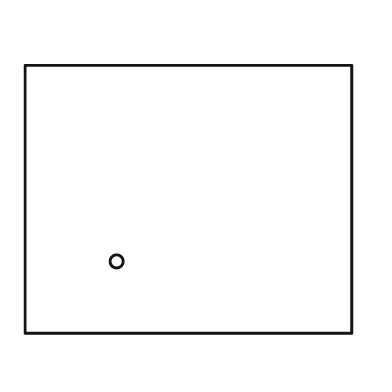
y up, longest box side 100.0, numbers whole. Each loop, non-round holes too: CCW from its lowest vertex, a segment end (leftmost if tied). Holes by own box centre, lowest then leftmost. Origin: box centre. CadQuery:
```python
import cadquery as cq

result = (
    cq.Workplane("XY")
    .moveTo(-50.0, -41.0)
    .lineTo(50.0, -41.0)
    .lineTo(50.0, 41.0)
    .lineTo(-50.0, 41.0)
    .close()
    .moveTo(-22.0, -19.0)
    .circle(2.0)
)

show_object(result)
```